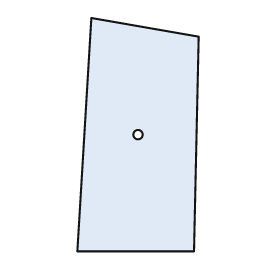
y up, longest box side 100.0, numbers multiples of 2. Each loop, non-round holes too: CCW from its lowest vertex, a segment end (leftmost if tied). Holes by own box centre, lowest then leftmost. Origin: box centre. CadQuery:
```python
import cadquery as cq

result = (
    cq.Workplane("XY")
    .moveTo(-26.0, -50.0)
    .lineTo(24.0, -50.0)
    .lineTo(26.0, 42.0)
    .lineTo(-20.0, 50.0)
    .close()
    .moveTo(0.0, 0.0)
    .circle(2.0)
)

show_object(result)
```